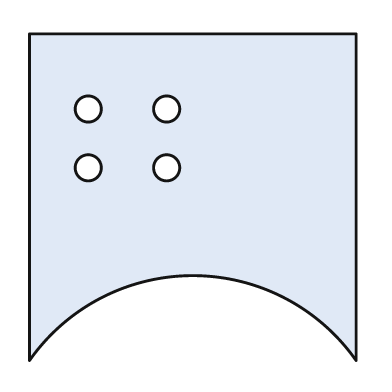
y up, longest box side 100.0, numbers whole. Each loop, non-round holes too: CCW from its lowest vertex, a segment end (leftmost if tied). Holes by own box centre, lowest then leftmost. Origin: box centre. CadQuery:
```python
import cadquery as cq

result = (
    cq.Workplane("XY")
    .moveTo(-50.0, -50.0)
    .threePointArc((0.0, -24.0), (50.0, -50.0))
    .lineTo(50.0, 50.0)
    .lineTo(-50.0, 50.0)
    .close()
    .moveTo(-32.0, 9.0)
    .circle(4.0)
    .moveTo(-8.0, 9.0)
    .circle(4.0)
    .moveTo(-32.0, 27.0)
    .circle(4.0)
    .moveTo(-8.0, 27.0)
    .circle(4.0)
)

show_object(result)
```